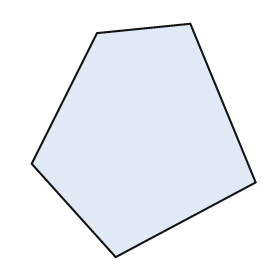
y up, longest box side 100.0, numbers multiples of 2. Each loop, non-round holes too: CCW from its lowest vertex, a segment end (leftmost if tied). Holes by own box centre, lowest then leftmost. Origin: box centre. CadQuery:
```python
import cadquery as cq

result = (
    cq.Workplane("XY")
    .moveTo(-12.0, -50.0)
    .lineTo(48.0, -18.0)
    .lineTo(20.0, 50.0)
    .lineTo(-20.0, 46.0)
    .lineTo(-48.0, -10.0)
    .close()
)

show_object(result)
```